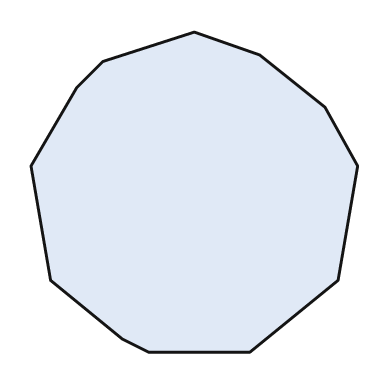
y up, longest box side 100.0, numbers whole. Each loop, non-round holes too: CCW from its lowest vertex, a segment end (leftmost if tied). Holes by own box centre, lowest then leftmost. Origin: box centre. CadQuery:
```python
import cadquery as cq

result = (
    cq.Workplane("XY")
    .moveTo(-14.0, -49.0)
    .lineTo(17.0, -49.0)
    .lineTo(44.0, -27.0)
    .lineTo(50.0, 8.0)
    .lineTo(40.0, 26.0)
    .lineTo(20.0, 42.0)
    .lineTo(0.0, 49.0)
    .lineTo(-28.0, 40.0)
    .lineTo(-36.0, 32.0)
    .lineTo(-50.0, 8.0)
    .lineTo(-44.0, -27.0)
    .lineTo(-22.0, -45.0)
    .close()
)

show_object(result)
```